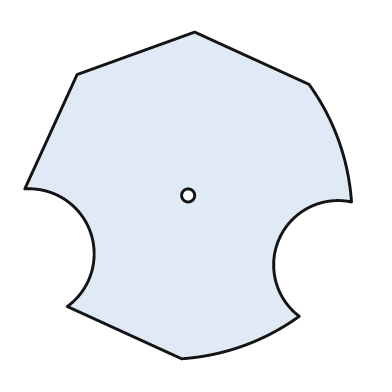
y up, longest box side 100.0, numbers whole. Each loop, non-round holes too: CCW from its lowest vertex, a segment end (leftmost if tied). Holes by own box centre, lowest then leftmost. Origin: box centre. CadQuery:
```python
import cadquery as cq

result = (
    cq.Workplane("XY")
    .moveTo(-2.0, -50.0)
    .threePointArc((17.0, -46.0), (34.0, -37.0))
    .threePointArc((28.0, -13.0), (50.0, -2.0))
    .threePointArc((46.0, 17.0), (37.0, 34.0))
    .lineTo(2.0, 50.0)
    .lineTo(-34.0, 37.0)
    .lineTo(-50.0, 2.0)
    .threePointArc((-30.0, -11.0), (-37.0, -34.0))
    .close()
    .moveTo(0.0, 0.0)
    .circle(2.0)
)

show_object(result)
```